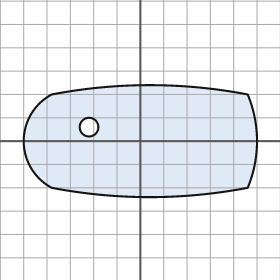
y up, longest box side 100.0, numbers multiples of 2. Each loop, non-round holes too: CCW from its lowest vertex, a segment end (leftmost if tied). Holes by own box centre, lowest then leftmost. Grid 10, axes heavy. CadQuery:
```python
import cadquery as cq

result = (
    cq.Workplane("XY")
    .moveTo(-38.0, -20.0)
    .threePointArc((4.0, -24.0), (46.0, -20.0))
    .threePointArc((50.0, 0.0), (46.0, 20.0))
    .threePointArc((4.0, 24.0), (-38.0, 20.0))
    .threePointArc((-50.0, 0.0), (-38.0, -20.0))
    .close()
    .moveTo(-22.0, 6.0)
    .circle(4.0)
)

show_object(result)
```